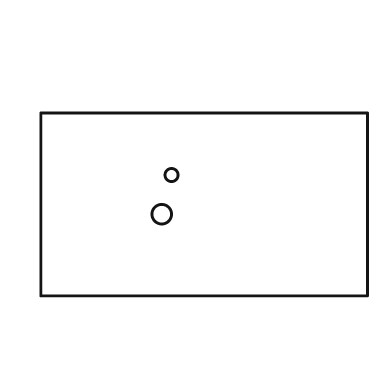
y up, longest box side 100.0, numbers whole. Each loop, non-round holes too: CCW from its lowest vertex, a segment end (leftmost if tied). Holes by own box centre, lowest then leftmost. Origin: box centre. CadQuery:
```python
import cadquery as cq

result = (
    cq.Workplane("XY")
    .moveTo(-50.0, -28.0)
    .lineTo(50.0, -28.0)
    .lineTo(50.0, 28.0)
    .lineTo(-50.0, 28.0)
    .close()
    .moveTo(-13.0, -3.0)
    .circle(3.0)
    .moveTo(-10.0, 9.0)
    .circle(2.0)
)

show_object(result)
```